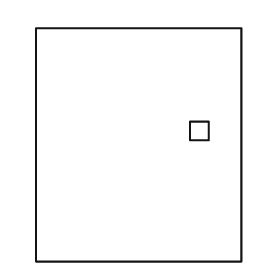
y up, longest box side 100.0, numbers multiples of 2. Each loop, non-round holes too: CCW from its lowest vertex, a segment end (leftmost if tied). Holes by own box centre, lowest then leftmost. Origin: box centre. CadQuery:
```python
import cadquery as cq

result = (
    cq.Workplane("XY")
    .moveTo(-44.0, -50.0)
    .lineTo(44.0, -50.0)
    .lineTo(44.0, 50.0)
    .lineTo(-44.0, 50.0)
    .close()
    .moveTo(22.0, 2.0)
    .lineTo(30.0, 2.0)
    .lineTo(30.0, 10.0)
    .lineTo(22.0, 10.0)
    .close()
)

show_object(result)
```